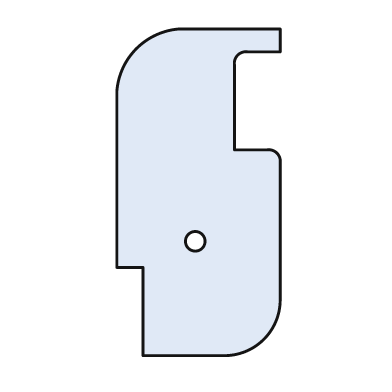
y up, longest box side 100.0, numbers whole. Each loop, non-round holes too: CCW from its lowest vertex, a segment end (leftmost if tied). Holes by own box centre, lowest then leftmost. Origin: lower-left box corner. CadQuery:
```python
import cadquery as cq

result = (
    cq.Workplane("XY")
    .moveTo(8.0, 0.0)
    .lineTo(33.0, 0.0)
    .threePointArc((45.0, 5.0), (50.0, 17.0))
    .lineTo(50.0, 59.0)
    .threePointArc((49.0, 62.0), (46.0, 63.0))
    .lineTo(36.0, 63.0)
    .lineTo(36.0, 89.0)
    .threePointArc((37.0, 92.0), (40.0, 93.0))
    .lineTo(50.0, 93.0)
    .lineTo(50.0, 100.0)
    .lineTo(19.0, 100.0)
    .threePointArc((6.0, 94.0), (0.0, 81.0))
    .lineTo(0.0, 27.0)
    .lineTo(8.0, 27.0)
    .close()
    .moveTo(24.0, 35.0)
    .circle(3.0)
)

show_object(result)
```